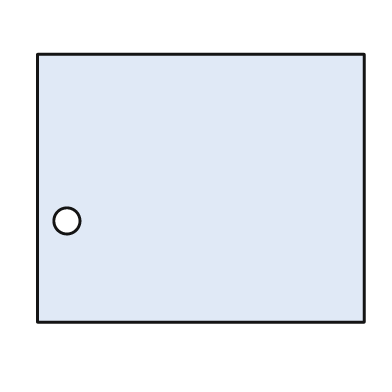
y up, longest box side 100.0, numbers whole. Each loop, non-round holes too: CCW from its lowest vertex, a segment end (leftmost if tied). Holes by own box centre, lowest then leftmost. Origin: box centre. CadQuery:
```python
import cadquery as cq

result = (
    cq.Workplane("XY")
    .moveTo(-50.0, -41.0)
    .lineTo(50.0, -41.0)
    .lineTo(50.0, 41.0)
    .lineTo(-50.0, 41.0)
    .close()
    .moveTo(-41.0, -10.0)
    .circle(4.0)
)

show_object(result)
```